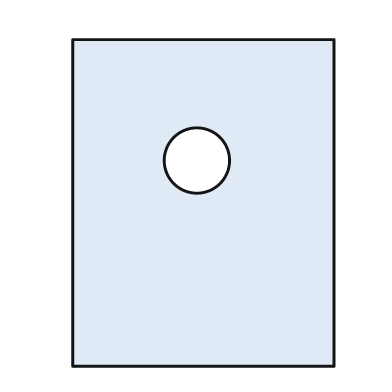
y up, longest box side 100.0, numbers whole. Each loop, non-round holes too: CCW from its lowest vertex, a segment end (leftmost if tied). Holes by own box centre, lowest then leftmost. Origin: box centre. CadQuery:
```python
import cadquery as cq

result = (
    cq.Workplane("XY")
    .moveTo(-40.0, -50.0)
    .lineTo(40.0, -50.0)
    .lineTo(40.0, 50.0)
    .lineTo(-40.0, 50.0)
    .close()
    .moveTo(-2.0, 13.0)
    .circle(10.0)
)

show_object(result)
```